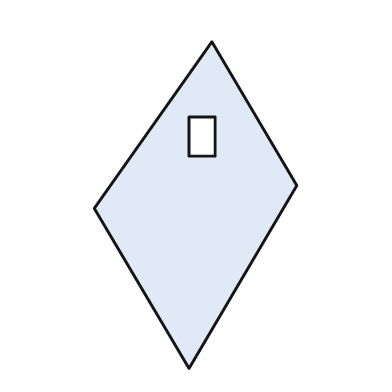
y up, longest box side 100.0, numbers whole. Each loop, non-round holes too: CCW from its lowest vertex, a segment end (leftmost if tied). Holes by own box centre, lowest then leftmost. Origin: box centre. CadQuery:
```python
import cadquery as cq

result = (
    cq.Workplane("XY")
    .moveTo(-2.0, -50.0)
    .lineTo(31.0, 6.0)
    .lineTo(5.0, 50.0)
    .lineTo(-31.0, -1.0)
    .close()
    .moveTo(-2.0, 15.0)
    .lineTo(6.0, 15.0)
    .lineTo(6.0, 27.0)
    .lineTo(-2.0, 27.0)
    .close()
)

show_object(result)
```